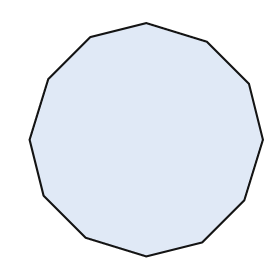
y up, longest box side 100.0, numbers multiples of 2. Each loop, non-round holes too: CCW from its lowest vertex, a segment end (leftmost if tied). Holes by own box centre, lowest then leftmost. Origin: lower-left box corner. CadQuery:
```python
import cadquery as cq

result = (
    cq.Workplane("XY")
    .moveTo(50.0, 0.0)
    .lineTo(74.0, 6.0)
    .lineTo(92.0, 24.0)
    .lineTo(100.0, 50.0)
    .lineTo(94.0, 74.0)
    .lineTo(76.0, 92.0)
    .lineTo(50.0, 100.0)
    .lineTo(26.0, 94.0)
    .lineTo(8.0, 76.0)
    .lineTo(0.0, 50.0)
    .lineTo(6.0, 26.0)
    .lineTo(24.0, 8.0)
    .close()
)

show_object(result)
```